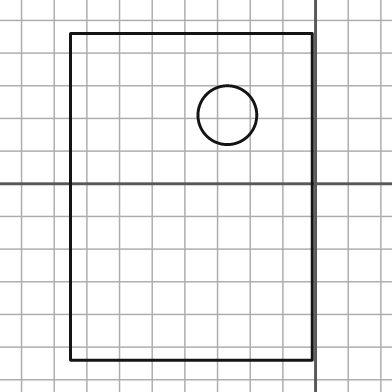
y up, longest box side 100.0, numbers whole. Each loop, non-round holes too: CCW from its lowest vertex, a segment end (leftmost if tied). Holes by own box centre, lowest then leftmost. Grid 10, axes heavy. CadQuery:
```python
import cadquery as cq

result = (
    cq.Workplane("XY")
    .moveTo(-75.0, -54.0)
    .lineTo(-1.0, -54.0)
    .lineTo(-1.0, 46.0)
    .lineTo(-75.0, 46.0)
    .close()
    .moveTo(-27.0, 21.0)
    .circle(9.0)
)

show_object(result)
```